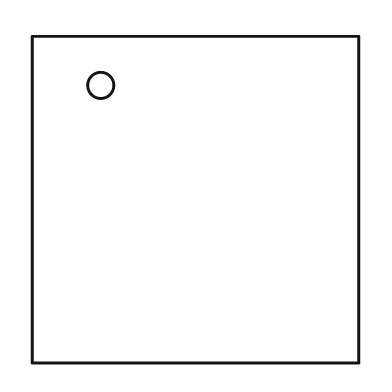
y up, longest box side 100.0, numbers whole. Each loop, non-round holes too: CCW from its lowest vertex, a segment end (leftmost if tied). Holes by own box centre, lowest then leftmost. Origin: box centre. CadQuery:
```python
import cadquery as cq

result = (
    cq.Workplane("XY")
    .moveTo(-50.0, -50.0)
    .lineTo(50.0, -50.0)
    .lineTo(50.0, 50.0)
    .lineTo(-50.0, 50.0)
    .close()
    .moveTo(-29.0, 35.0)
    .circle(4.0)
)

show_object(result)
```